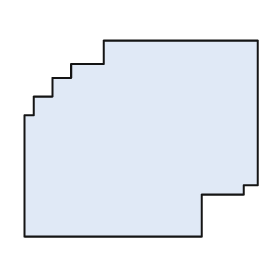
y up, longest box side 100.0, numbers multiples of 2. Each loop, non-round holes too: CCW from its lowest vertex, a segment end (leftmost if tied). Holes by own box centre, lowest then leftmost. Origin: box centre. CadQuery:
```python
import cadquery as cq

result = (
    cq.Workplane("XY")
    .moveTo(-50.0, -42.0)
    .lineTo(26.0, -42.0)
    .lineTo(26.0, -24.0)
    .lineTo(44.0, -24.0)
    .lineTo(44.0, -20.0)
    .lineTo(50.0, -20.0)
    .lineTo(50.0, 42.0)
    .lineTo(-16.0, 42.0)
    .lineTo(-16.0, 32.0)
    .lineTo(-30.0, 32.0)
    .lineTo(-30.0, 26.0)
    .lineTo(-38.0, 26.0)
    .lineTo(-38.0, 18.0)
    .lineTo(-46.0, 18.0)
    .lineTo(-46.0, 10.0)
    .lineTo(-50.0, 10.0)
    .close()
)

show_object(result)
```